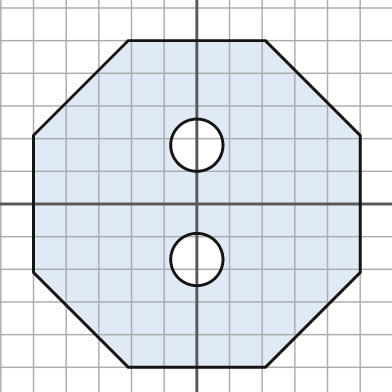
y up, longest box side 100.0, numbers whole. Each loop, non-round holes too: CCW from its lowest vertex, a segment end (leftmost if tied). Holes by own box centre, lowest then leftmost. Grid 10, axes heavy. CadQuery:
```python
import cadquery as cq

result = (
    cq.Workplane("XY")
    .moveTo(-21.0, -50.0)
    .lineTo(21.0, -50.0)
    .lineTo(50.0, -21.0)
    .lineTo(50.0, 21.0)
    .lineTo(21.0, 50.0)
    .lineTo(-21.0, 50.0)
    .lineTo(-50.0, 21.0)
    .lineTo(-50.0, -21.0)
    .close()
    .moveTo(0.0, -17.0)
    .circle(8.0)
    .moveTo(0.0, 18.0)
    .circle(8.0)
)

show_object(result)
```